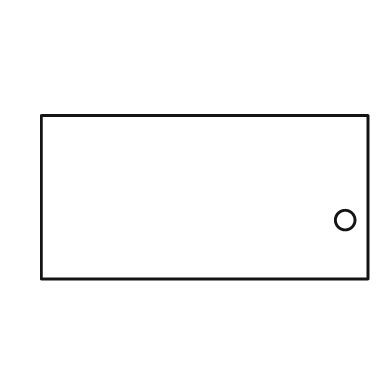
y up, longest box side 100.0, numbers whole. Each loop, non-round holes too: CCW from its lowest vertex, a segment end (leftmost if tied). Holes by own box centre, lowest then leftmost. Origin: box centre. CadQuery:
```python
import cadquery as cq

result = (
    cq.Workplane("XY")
    .moveTo(-50.0, -25.0)
    .lineTo(50.0, -25.0)
    .lineTo(50.0, 25.0)
    .lineTo(-50.0, 25.0)
    .close()
    .moveTo(43.0, -7.0)
    .circle(3.0)
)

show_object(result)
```